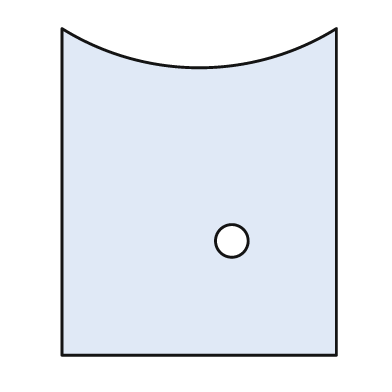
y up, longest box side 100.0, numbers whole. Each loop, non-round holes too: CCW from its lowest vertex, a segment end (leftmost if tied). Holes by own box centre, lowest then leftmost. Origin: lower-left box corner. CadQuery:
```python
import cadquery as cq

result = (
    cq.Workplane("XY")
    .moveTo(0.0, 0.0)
    .lineTo(84.0, 0.0)
    .lineTo(84.0, 100.0)
    .threePointArc((42.0, 88.0), (0.0, 100.0))
    .close()
    .moveTo(52.0, 35.0)
    .circle(5.0)
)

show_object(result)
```